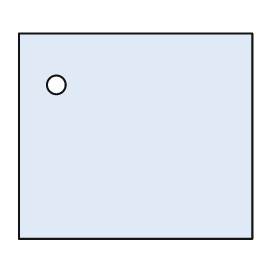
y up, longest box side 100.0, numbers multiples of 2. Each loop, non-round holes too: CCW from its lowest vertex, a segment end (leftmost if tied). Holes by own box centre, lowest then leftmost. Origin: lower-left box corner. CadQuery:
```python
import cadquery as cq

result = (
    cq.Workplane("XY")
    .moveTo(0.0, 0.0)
    .lineTo(100.0, 0.0)
    .lineTo(100.0, 88.0)
    .lineTo(0.0, 88.0)
    .close()
    .moveTo(16.0, 66.0)
    .circle(4.0)
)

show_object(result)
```